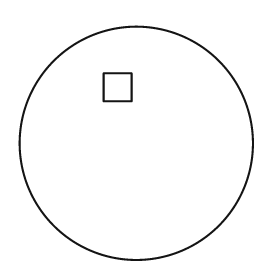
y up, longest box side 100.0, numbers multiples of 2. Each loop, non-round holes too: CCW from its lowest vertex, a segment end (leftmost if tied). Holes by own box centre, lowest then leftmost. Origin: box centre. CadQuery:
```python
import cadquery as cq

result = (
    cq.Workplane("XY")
    .moveTo(0.0, 0.0)
    .circle(50.0)
    .moveTo(-14.0, 18.0)
    .lineTo(-2.0, 18.0)
    .lineTo(-2.0, 30.0)
    .lineTo(-14.0, 30.0)
    .close()
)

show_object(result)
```